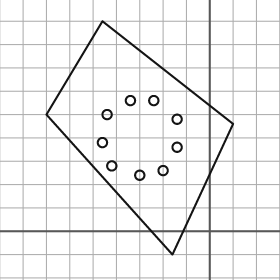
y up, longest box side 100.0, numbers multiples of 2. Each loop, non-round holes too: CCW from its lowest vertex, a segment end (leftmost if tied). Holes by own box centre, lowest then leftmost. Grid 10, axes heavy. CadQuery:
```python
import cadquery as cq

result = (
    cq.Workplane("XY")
    .moveTo(-16.0, -10.0)
    .lineTo(10.0, 46.0)
    .lineTo(-46.0, 90.0)
    .lineTo(-70.0, 50.0)
    .close()
    .moveTo(-30.0, 24.0)
    .circle(2.0)
    .moveTo(-20.0, 26.0)
    .circle(2.0)
    .moveTo(-42.0, 28.0)
    .circle(2.0)
    .moveTo(-14.0, 36.0)
    .circle(2.0)
    .moveTo(-46.0, 38.0)
    .circle(2.0)
    .moveTo(-14.0, 48.0)
    .circle(2.0)
    .moveTo(-44.0, 50.0)
    .circle(2.0)
    .moveTo(-34.0, 56.0)
    .circle(2.0)
    .moveTo(-24.0, 56.0)
    .circle(2.0)
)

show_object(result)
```